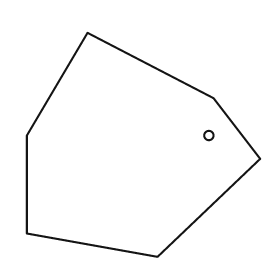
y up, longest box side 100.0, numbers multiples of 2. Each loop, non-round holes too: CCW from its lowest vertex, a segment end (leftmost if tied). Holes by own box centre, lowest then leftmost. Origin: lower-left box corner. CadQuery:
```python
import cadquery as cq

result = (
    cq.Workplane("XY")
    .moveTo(56.0, 0.0)
    .lineTo(100.0, 42.0)
    .lineTo(80.0, 68.0)
    .lineTo(26.0, 96.0)
    .lineTo(0.0, 52.0)
    .lineTo(0.0, 10.0)
    .close()
    .moveTo(78.0, 52.0)
    .circle(2.0)
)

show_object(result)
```